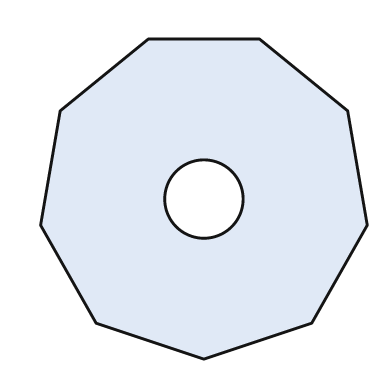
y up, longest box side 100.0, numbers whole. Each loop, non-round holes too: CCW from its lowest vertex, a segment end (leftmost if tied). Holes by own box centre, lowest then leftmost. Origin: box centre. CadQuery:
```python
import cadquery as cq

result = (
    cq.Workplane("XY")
    .moveTo(0.0, -49.0)
    .lineTo(33.0, -38.0)
    .lineTo(50.0, -8.0)
    .lineTo(44.0, 27.0)
    .lineTo(17.0, 49.0)
    .lineTo(-17.0, 49.0)
    .lineTo(-44.0, 27.0)
    .lineTo(-50.0, -8.0)
    .lineTo(-33.0, -38.0)
    .close()
    .moveTo(0.0, 0.0)
    .circle(12.0)
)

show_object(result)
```